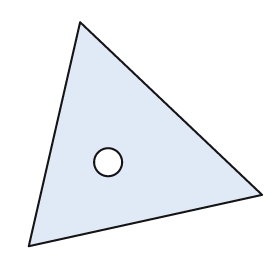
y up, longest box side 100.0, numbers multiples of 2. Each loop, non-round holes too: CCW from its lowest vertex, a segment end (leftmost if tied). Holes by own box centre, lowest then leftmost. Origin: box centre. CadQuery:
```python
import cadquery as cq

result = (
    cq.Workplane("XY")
    .moveTo(-50.0, -48.0)
    .lineTo(50.0, -26.0)
    .lineTo(-28.0, 48.0)
    .close()
    .moveTo(-16.0, -12.0)
    .circle(6.0)
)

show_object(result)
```